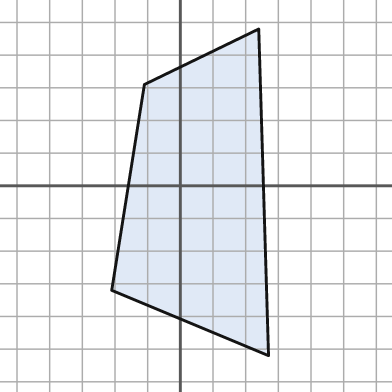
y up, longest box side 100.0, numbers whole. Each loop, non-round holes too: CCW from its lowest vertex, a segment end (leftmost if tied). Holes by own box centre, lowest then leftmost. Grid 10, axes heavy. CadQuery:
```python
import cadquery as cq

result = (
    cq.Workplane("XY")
    .moveTo(27.0, -52.0)
    .lineTo(24.0, 48.0)
    .lineTo(-11.0, 31.0)
    .lineTo(-21.0, -32.0)
    .close()
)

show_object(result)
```